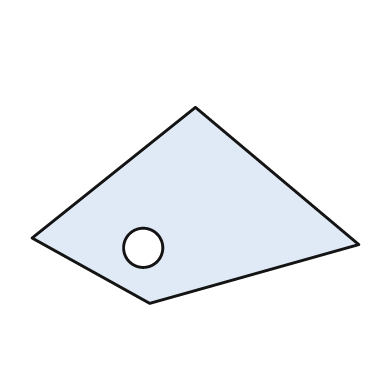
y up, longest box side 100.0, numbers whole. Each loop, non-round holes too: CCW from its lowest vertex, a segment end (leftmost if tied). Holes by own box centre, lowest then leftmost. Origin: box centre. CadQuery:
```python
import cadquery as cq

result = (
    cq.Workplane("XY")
    .moveTo(-14.0, -30.0)
    .lineTo(50.0, -12.0)
    .lineTo(0.0, 30.0)
    .lineTo(-50.0, -10.0)
    .close()
    .moveTo(-16.0, -13.0)
    .circle(6.0)
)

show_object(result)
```